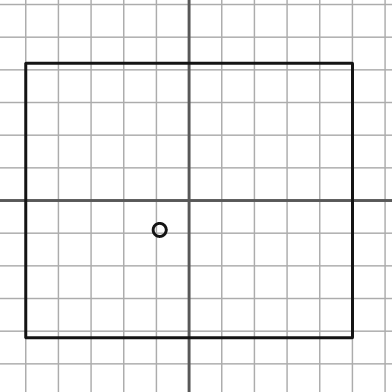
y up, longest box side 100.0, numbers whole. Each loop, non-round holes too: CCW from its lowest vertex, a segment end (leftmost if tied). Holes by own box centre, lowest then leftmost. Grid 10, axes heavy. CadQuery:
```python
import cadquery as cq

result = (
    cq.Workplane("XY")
    .moveTo(-50.0, -42.0)
    .lineTo(50.0, -42.0)
    .lineTo(50.0, 42.0)
    .lineTo(-50.0, 42.0)
    .close()
    .moveTo(-9.0, -9.0)
    .circle(2.0)
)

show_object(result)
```